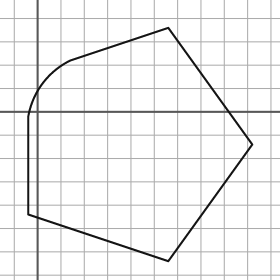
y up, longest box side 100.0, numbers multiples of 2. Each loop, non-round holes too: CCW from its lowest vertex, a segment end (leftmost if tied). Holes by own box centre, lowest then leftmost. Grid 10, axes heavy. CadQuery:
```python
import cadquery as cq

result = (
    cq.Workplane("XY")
    .moveTo(56.0, -64.0)
    .lineTo(92.0, -14.0)
    .lineTo(56.0, 36.0)
    .lineTo(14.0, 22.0)
    .threePointArc((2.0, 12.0), (-4.0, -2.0))
    .lineTo(-4.0, -44.0)
    .close()
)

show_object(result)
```